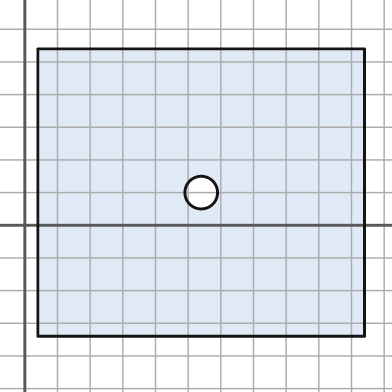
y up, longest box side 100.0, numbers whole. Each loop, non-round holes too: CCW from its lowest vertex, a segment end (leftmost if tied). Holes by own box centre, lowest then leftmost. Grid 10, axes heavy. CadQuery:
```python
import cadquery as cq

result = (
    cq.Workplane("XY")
    .moveTo(4.0, -34.0)
    .lineTo(104.0, -34.0)
    .lineTo(104.0, 54.0)
    .lineTo(4.0, 54.0)
    .close()
    .moveTo(54.0, 10.0)
    .circle(5.0)
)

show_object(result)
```